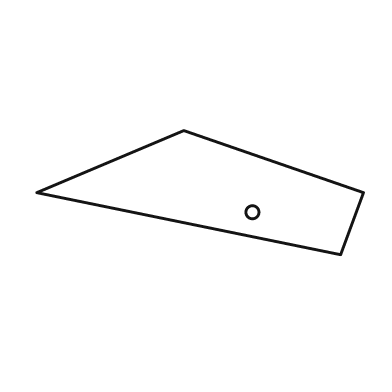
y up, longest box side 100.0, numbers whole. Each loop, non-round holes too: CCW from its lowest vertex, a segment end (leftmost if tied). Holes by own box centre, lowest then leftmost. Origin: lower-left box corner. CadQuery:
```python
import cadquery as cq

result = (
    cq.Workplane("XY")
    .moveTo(93.0, 0.0)
    .lineTo(100.0, 19.0)
    .lineTo(45.0, 38.0)
    .lineTo(0.0, 19.0)
    .close()
    .moveTo(66.0, 13.0)
    .circle(2.0)
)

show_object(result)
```